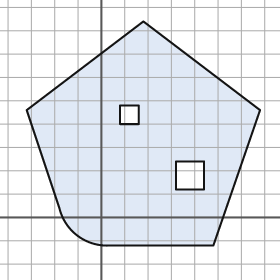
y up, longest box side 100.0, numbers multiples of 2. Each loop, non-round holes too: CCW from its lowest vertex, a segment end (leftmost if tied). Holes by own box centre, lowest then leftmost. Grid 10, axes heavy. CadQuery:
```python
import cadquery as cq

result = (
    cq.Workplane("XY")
    .moveTo(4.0, -12.0)
    .lineTo(48.0, -12.0)
    .lineTo(68.0, 46.0)
    .lineTo(18.0, 84.0)
    .lineTo(-32.0, 46.0)
    .lineTo(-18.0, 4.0)
    .threePointArc((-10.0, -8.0), (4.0, -12.0))
    .close()
    .moveTo(32.0, 12.0)
    .lineTo(44.0, 12.0)
    .lineTo(44.0, 24.0)
    .lineTo(32.0, 24.0)
    .close()
    .moveTo(8.0, 40.0)
    .lineTo(16.0, 40.0)
    .lineTo(16.0, 48.0)
    .lineTo(8.0, 48.0)
    .close()
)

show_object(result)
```